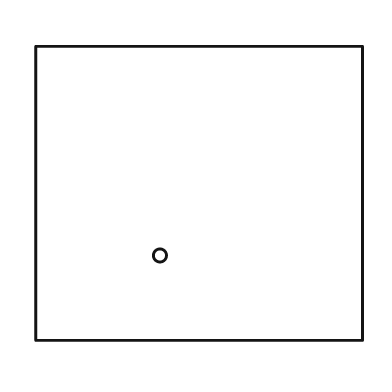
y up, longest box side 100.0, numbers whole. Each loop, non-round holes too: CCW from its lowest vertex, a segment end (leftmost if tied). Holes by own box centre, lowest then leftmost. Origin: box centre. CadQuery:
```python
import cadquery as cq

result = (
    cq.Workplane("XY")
    .moveTo(-50.0, -45.0)
    .lineTo(50.0, -45.0)
    .lineTo(50.0, 45.0)
    .lineTo(-50.0, 45.0)
    .close()
    .moveTo(-12.0, -19.0)
    .circle(2.0)
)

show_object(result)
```